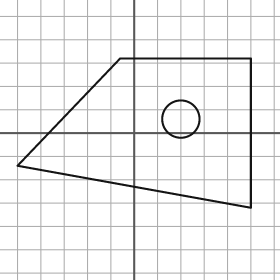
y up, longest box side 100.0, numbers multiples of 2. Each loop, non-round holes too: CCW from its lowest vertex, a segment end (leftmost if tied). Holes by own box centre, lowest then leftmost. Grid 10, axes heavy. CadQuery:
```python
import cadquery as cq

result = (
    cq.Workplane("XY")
    .moveTo(50.0, -32.0)
    .lineTo(50.0, 32.0)
    .lineTo(-6.0, 32.0)
    .lineTo(-50.0, -14.0)
    .close()
    .moveTo(20.0, 6.0)
    .circle(8.0)
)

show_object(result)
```